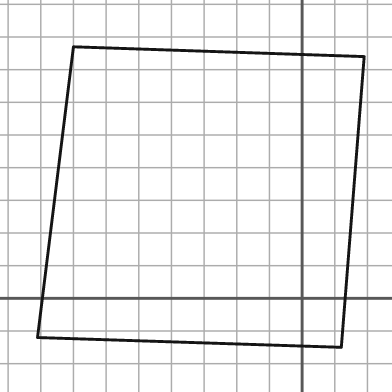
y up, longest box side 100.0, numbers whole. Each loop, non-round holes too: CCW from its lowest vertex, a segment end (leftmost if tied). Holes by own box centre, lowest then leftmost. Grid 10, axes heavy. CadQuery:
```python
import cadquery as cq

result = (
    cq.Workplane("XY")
    .moveTo(12.0, -15.0)
    .lineTo(19.0, 74.0)
    .lineTo(-70.0, 77.0)
    .lineTo(-81.0, -12.0)
    .close()
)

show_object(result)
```